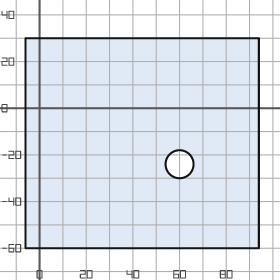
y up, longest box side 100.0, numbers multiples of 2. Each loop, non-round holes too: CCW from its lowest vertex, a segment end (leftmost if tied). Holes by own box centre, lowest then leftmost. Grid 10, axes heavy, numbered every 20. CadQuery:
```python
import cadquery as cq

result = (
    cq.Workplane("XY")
    .moveTo(-6.0, -60.0)
    .lineTo(94.0, -60.0)
    .lineTo(94.0, 30.0)
    .lineTo(-6.0, 30.0)
    .close()
    .moveTo(60.0, -24.0)
    .circle(6.0)
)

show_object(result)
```